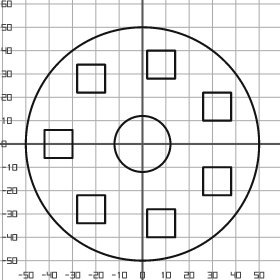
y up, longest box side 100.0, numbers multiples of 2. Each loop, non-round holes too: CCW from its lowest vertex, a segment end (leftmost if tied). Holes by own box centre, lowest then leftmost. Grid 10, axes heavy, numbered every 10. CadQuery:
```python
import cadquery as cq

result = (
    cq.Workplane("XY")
    .moveTo(0.0, 0.0)
    .circle(50.0)
    .moveTo(2.0, -40.0)
    .lineTo(14.0, -40.0)
    .lineTo(14.0, -28.0)
    .lineTo(2.0, -28.0)
    .close()
    .moveTo(-28.0, -34.0)
    .lineTo(-16.0, -34.0)
    .lineTo(-16.0, -22.0)
    .lineTo(-28.0, -22.0)
    .close()
    .moveTo(26.0, -22.0)
    .lineTo(38.0, -22.0)
    .lineTo(38.0, -10.0)
    .lineTo(26.0, -10.0)
    .close()
    .moveTo(-42.0, -6.0)
    .lineTo(-30.0, -6.0)
    .lineTo(-30.0, 6.0)
    .lineTo(-42.0, 6.0)
    .close()
    .moveTo(0.0, 0.0)
    .circle(12.0)
    .moveTo(26.0, 10.0)
    .lineTo(38.0, 10.0)
    .lineTo(38.0, 22.0)
    .lineTo(26.0, 22.0)
    .close()
    .moveTo(-28.0, 22.0)
    .lineTo(-16.0, 22.0)
    .lineTo(-16.0, 34.0)
    .lineTo(-28.0, 34.0)
    .close()
    .moveTo(2.0, 28.0)
    .lineTo(14.0, 28.0)
    .lineTo(14.0, 40.0)
    .lineTo(2.0, 40.0)
    .close()
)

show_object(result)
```